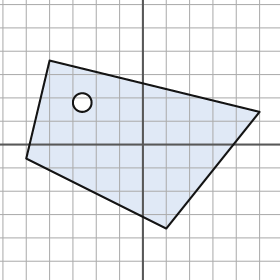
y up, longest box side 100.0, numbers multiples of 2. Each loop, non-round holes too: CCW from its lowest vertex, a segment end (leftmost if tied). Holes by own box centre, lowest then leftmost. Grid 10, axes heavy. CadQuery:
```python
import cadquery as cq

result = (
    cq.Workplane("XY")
    .moveTo(10.0, -36.0)
    .lineTo(50.0, 14.0)
    .lineTo(-40.0, 36.0)
    .lineTo(-50.0, -6.0)
    .close()
    .moveTo(-26.0, 18.0)
    .circle(4.0)
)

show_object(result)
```